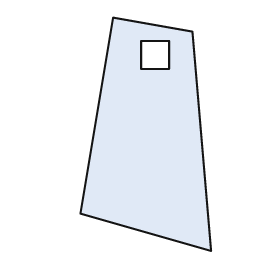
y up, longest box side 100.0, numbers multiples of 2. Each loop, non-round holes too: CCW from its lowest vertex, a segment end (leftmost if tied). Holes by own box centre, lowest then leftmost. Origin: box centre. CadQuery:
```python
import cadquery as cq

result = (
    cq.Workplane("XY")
    .moveTo(28.0, -50.0)
    .lineTo(20.0, 44.0)
    .lineTo(-14.0, 50.0)
    .lineTo(-28.0, -34.0)
    .close()
    .moveTo(-2.0, 28.0)
    .lineTo(10.0, 28.0)
    .lineTo(10.0, 40.0)
    .lineTo(-2.0, 40.0)
    .close()
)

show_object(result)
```